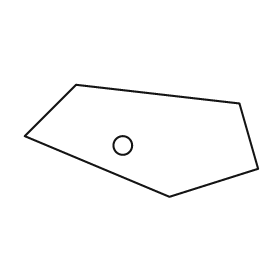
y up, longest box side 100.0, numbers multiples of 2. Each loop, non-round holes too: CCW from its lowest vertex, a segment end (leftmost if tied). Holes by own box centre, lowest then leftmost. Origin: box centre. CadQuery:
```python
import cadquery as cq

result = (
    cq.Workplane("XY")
    .moveTo(12.0, -24.0)
    .lineTo(50.0, -12.0)
    .lineTo(42.0, 16.0)
    .lineTo(-28.0, 24.0)
    .lineTo(-50.0, 2.0)
    .close()
    .moveTo(-8.0, -2.0)
    .circle(4.0)
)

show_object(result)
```